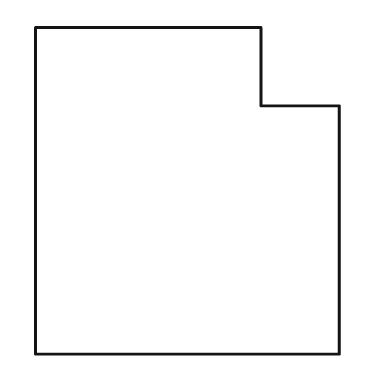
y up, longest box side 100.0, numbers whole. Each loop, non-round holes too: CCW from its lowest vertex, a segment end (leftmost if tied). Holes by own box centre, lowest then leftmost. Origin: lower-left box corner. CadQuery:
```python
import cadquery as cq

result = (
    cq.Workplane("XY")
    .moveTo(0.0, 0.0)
    .lineTo(93.0, 0.0)
    .lineTo(93.0, 76.0)
    .lineTo(69.0, 76.0)
    .lineTo(69.0, 100.0)
    .lineTo(0.0, 100.0)
    .close()
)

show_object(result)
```